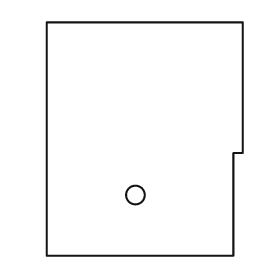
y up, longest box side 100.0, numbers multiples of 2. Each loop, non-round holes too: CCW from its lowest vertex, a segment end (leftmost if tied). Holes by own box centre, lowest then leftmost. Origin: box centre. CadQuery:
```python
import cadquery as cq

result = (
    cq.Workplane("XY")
    .moveTo(-42.0, -50.0)
    .lineTo(38.0, -50.0)
    .lineTo(38.0, -6.0)
    .lineTo(42.0, -6.0)
    .lineTo(42.0, 50.0)
    .lineTo(-42.0, 50.0)
    .close()
    .moveTo(-4.0, -24.0)
    .circle(4.0)
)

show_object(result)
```